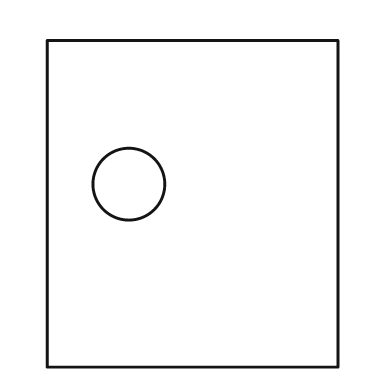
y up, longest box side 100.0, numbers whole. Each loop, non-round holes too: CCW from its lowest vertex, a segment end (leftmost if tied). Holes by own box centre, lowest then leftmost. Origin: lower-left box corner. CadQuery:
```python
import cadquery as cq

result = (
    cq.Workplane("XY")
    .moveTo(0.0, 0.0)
    .lineTo(89.0, 0.0)
    .lineTo(89.0, 100.0)
    .lineTo(0.0, 100.0)
    .close()
    .moveTo(25.0, 56.0)
    .circle(11.0)
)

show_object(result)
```